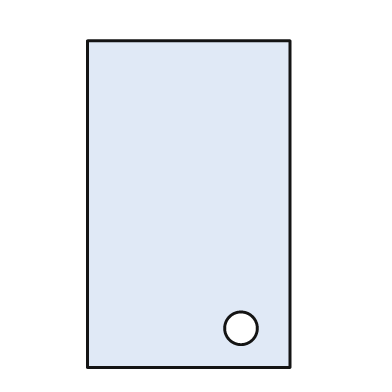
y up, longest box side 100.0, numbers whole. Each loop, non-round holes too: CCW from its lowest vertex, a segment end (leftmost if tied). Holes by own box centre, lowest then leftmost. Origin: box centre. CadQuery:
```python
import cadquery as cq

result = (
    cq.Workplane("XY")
    .moveTo(-31.0, -50.0)
    .lineTo(31.0, -50.0)
    .lineTo(31.0, 50.0)
    .lineTo(-31.0, 50.0)
    .close()
    .moveTo(16.0, -38.0)
    .circle(5.0)
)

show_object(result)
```